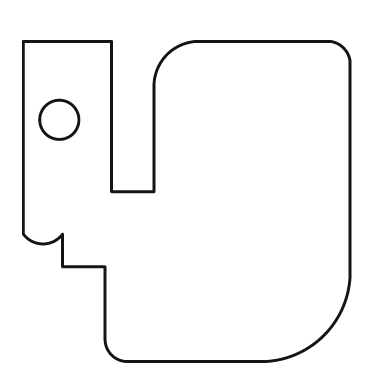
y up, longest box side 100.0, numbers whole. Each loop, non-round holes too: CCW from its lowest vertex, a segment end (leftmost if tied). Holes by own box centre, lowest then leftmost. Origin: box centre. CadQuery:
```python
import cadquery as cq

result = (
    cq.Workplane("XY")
    .moveTo(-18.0, -49.0)
    .lineTo(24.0, -49.0)
    .threePointArc((42.0, -41.0), (50.0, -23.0))
    .lineTo(50.0, 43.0)
    .threePointArc((48.0, 47.0), (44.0, 49.0))
    .lineTo(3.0, 49.0)
    .threePointArc((-6.0, 45.0), (-10.0, 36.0))
    .lineTo(-10.0, 3.0)
    .lineTo(-23.0, 3.0)
    .lineTo(-23.0, 49.0)
    .lineTo(-50.0, 49.0)
    .lineTo(-50.0, -10.0)
    .threePointArc((-44.0, -13.0), (-38.0, -10.0))
    .lineTo(-38.0, -20.0)
    .lineTo(-25.0, -20.0)
    .lineTo(-25.0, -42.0)
    .threePointArc((-23.0, -47.0), (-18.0, -49.0))
    .close()
    .moveTo(-39.0, 25.0)
    .circle(6.0)
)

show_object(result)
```